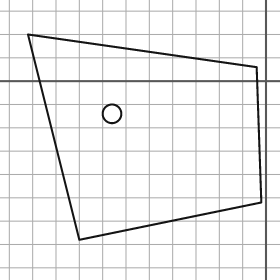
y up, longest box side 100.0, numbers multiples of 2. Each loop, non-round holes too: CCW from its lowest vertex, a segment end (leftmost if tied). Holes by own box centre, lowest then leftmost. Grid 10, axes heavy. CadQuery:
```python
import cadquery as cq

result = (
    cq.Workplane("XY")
    .moveTo(-80.0, -68.0)
    .lineTo(-2.0, -52.0)
    .lineTo(-4.0, 6.0)
    .lineTo(-102.0, 20.0)
    .close()
    .moveTo(-66.0, -14.0)
    .circle(4.0)
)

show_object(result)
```